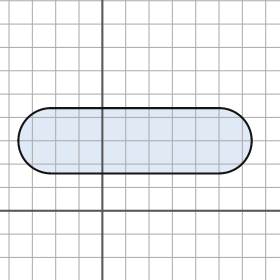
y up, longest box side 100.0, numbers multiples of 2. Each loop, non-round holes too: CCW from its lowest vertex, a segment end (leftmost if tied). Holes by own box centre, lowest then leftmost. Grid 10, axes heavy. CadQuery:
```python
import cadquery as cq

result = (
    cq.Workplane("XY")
    .moveTo(-22.0, 16.0)
    .lineTo(50.0, 16.0)
    .threePointArc((64.0, 30.0), (50.0, 44.0))
    .lineTo(-22.0, 44.0)
    .threePointArc((-36.0, 30.0), (-22.0, 16.0))
    .close()
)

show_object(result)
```